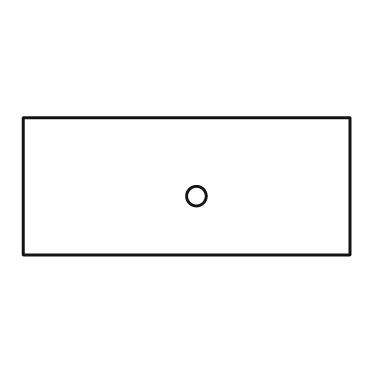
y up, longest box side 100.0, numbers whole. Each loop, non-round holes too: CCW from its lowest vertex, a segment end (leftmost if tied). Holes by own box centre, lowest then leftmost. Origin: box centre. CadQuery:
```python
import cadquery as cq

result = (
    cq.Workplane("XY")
    .moveTo(-50.0, -21.0)
    .lineTo(50.0, -21.0)
    .lineTo(50.0, 21.0)
    .lineTo(-50.0, 21.0)
    .close()
    .moveTo(3.0, -3.0)
    .circle(3.0)
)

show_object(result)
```